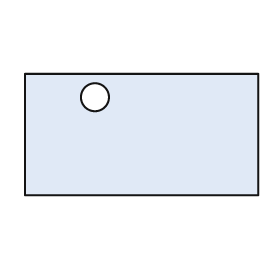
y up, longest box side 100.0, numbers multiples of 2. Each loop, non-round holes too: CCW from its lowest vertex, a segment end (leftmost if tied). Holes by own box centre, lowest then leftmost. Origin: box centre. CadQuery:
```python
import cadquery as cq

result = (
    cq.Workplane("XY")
    .moveTo(-50.0, -26.0)
    .lineTo(50.0, -26.0)
    .lineTo(50.0, 26.0)
    .lineTo(-50.0, 26.0)
    .close()
    .moveTo(-20.0, 16.0)
    .circle(6.0)
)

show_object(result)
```